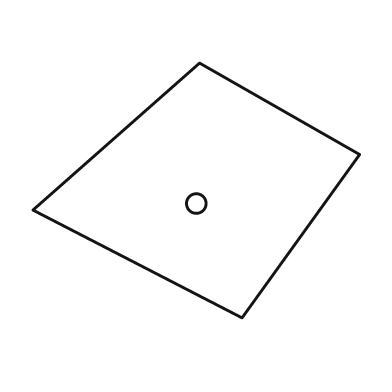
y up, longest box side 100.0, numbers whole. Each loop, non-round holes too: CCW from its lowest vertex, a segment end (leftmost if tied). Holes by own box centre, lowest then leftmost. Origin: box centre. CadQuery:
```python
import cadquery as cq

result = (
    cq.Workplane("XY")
    .moveTo(14.0, -39.0)
    .lineTo(50.0, 11.0)
    .lineTo(1.0, 39.0)
    .lineTo(-50.0, -6.0)
    .close()
    .moveTo(0.0, -4.0)
    .circle(3.0)
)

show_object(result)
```